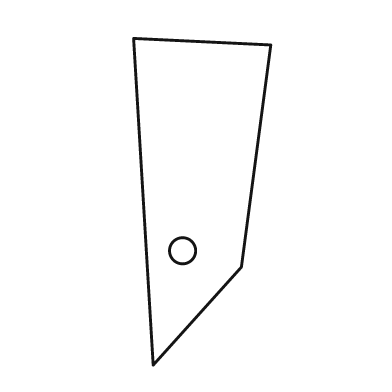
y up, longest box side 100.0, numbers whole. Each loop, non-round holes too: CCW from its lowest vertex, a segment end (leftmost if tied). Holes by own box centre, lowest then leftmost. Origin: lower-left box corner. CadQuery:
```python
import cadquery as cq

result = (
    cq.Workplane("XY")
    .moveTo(6.0, 0.0)
    .lineTo(33.0, 30.0)
    .lineTo(42.0, 98.0)
    .lineTo(0.0, 100.0)
    .close()
    .moveTo(15.0, 35.0)
    .circle(4.0)
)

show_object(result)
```